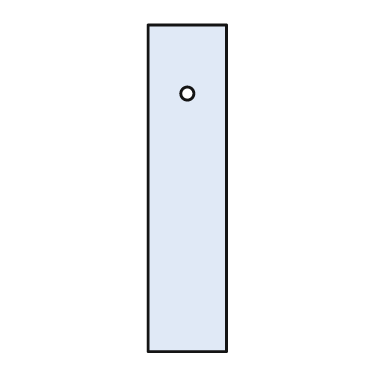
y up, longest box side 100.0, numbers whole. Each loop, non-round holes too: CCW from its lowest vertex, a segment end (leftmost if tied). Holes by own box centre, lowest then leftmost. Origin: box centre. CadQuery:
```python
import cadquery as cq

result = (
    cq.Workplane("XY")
    .moveTo(-12.0, -50.0)
    .lineTo(12.0, -50.0)
    .lineTo(12.0, 50.0)
    .lineTo(-12.0, 50.0)
    .close()
    .moveTo(0.0, 29.0)
    .circle(2.0)
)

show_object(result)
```